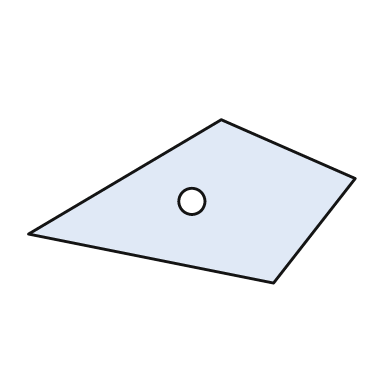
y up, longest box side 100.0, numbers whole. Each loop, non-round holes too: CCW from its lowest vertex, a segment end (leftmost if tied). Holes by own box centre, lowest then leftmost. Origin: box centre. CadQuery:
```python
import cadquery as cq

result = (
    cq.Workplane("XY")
    .moveTo(25.0, -25.0)
    .lineTo(50.0, 7.0)
    .lineTo(9.0, 25.0)
    .lineTo(-50.0, -10.0)
    .close()
    .moveTo(0.0, 0.0)
    .circle(4.0)
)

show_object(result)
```